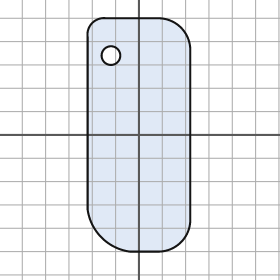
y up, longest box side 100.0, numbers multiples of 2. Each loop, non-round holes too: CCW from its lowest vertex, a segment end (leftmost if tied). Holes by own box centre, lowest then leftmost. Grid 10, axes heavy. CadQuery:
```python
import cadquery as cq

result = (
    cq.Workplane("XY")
    .moveTo(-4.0, -50.0)
    .lineTo(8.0, -50.0)
    .threePointArc((18.0, -46.0), (22.0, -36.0))
    .lineTo(22.0, 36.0)
    .threePointArc((18.0, 46.0), (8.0, 50.0))
    .lineTo(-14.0, 50.0)
    .threePointArc((-20.0, 48.0), (-22.0, 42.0))
    .lineTo(-22.0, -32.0)
    .threePointArc((-16.0, -44.0), (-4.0, -50.0))
    .close()
    .moveTo(-12.0, 34.0)
    .circle(4.0)
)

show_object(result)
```